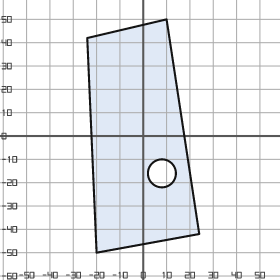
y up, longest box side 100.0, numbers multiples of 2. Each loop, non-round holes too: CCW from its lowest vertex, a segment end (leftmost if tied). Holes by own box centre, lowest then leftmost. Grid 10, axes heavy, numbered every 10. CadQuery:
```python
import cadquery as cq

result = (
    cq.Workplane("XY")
    .moveTo(-20.0, -50.0)
    .lineTo(24.0, -42.0)
    .lineTo(10.0, 50.0)
    .lineTo(-24.0, 42.0)
    .close()
    .moveTo(8.0, -16.0)
    .circle(6.0)
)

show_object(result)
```